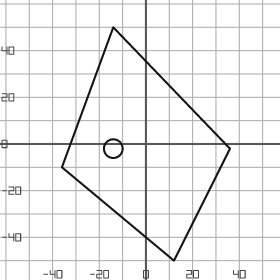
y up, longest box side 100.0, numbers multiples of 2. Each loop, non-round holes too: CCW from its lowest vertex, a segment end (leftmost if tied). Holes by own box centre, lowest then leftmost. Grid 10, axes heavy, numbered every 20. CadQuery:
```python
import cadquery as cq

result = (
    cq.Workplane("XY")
    .moveTo(12.0, -50.0)
    .lineTo(36.0, -2.0)
    .lineTo(-14.0, 50.0)
    .lineTo(-36.0, -10.0)
    .close()
    .moveTo(-14.0, -2.0)
    .circle(4.0)
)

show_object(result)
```